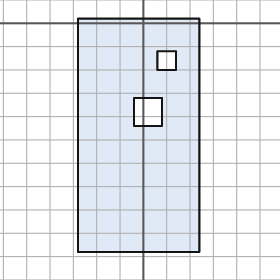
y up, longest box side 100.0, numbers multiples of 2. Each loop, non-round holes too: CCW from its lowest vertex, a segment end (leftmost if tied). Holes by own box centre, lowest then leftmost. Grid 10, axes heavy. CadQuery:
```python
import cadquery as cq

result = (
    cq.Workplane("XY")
    .moveTo(-28.0, -98.0)
    .lineTo(24.0, -98.0)
    .lineTo(24.0, 2.0)
    .lineTo(-28.0, 2.0)
    .close()
    .moveTo(-4.0, -44.0)
    .lineTo(8.0, -44.0)
    .lineTo(8.0, -32.0)
    .lineTo(-4.0, -32.0)
    .close()
    .moveTo(6.0, -20.0)
    .lineTo(14.0, -20.0)
    .lineTo(14.0, -12.0)
    .lineTo(6.0, -12.0)
    .close()
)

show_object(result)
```